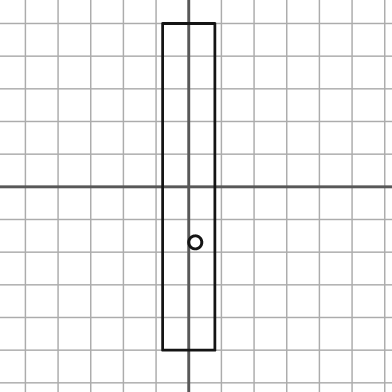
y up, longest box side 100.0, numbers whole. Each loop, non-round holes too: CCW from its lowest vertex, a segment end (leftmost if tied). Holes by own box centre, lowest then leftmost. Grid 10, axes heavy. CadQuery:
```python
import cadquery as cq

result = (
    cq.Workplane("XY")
    .moveTo(-8.0, -50.0)
    .lineTo(8.0, -50.0)
    .lineTo(8.0, 50.0)
    .lineTo(-8.0, 50.0)
    .close()
    .moveTo(2.0, -17.0)
    .circle(2.0)
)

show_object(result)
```